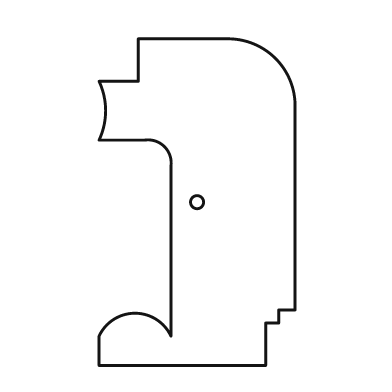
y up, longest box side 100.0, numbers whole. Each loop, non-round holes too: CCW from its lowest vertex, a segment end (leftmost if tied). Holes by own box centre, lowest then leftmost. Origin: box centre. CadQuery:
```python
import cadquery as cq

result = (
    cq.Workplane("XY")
    .moveTo(-30.0, -50.0)
    .lineTo(21.0, -50.0)
    .lineTo(21.0, -37.0)
    .lineTo(25.0, -37.0)
    .lineTo(25.0, -33.0)
    .lineTo(30.0, -33.0)
    .lineTo(30.0, 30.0)
    .threePointArc((24.0, 44.0), (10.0, 50.0))
    .lineTo(-18.0, 50.0)
    .lineTo(-18.0, 37.0)
    .lineTo(-30.0, 37.0)
    .threePointArc((-28.0, 28.0), (-30.0, 19.0))
    .lineTo(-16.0, 19.0)
    .threePointArc((-10.0, 17.0), (-8.0, 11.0))
    .lineTo(-8.0, -41.0)
    .threePointArc((-19.0, -34.0), (-30.0, -41.0))
    .close()
    .moveTo(0.0, 0.0)
    .circle(2.0)
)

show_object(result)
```